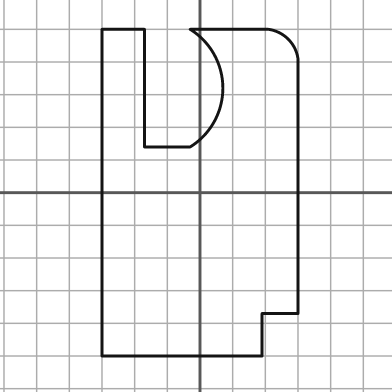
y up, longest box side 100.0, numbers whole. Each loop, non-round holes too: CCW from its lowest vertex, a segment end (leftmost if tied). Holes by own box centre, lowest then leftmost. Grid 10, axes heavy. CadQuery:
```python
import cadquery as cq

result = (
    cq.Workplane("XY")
    .moveTo(-30.0, -50.0)
    .lineTo(19.0, -50.0)
    .lineTo(19.0, -37.0)
    .lineTo(30.0, -37.0)
    .lineTo(30.0, 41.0)
    .threePointArc((27.0, 47.0), (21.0, 50.0))
    .lineTo(-3.0, 50.0)
    .threePointArc((7.0, 32.0), (-3.0, 14.0))
    .lineTo(-17.0, 14.0)
    .lineTo(-17.0, 50.0)
    .lineTo(-30.0, 50.0)
    .close()
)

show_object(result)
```